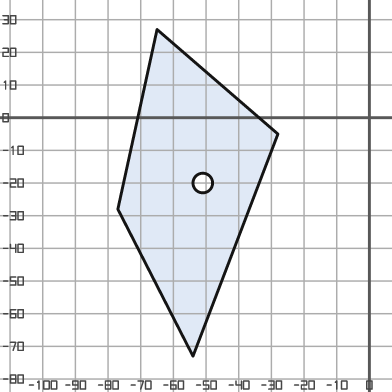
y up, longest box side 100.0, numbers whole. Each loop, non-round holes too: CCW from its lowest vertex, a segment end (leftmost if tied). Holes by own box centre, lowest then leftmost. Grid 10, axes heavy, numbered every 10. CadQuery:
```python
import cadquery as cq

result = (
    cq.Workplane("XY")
    .moveTo(-54.0, -73.0)
    .lineTo(-28.0, -5.0)
    .lineTo(-65.0, 27.0)
    .lineTo(-77.0, -28.0)
    .close()
    .moveTo(-51.0, -20.0)
    .circle(3.0)
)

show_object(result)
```